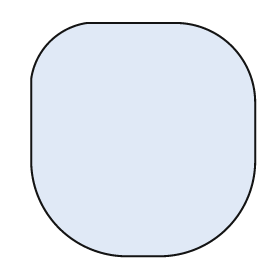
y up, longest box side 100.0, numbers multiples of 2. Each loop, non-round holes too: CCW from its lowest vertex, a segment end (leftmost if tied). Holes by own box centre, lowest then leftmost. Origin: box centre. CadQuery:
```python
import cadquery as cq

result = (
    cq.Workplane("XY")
    .moveTo(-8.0, -50.0)
    .lineTo(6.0, -50.0)
    .threePointArc((36.0, -38.0), (48.0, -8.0))
    .lineTo(48.0, 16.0)
    .threePointArc((38.0, 40.0), (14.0, 50.0))
    .lineTo(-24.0, 50.0)
    .threePointArc((-40.0, 42.0), (-48.0, 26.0))
    .lineTo(-48.0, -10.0)
    .threePointArc((-36.0, -38.0), (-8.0, -50.0))
    .close()
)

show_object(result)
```